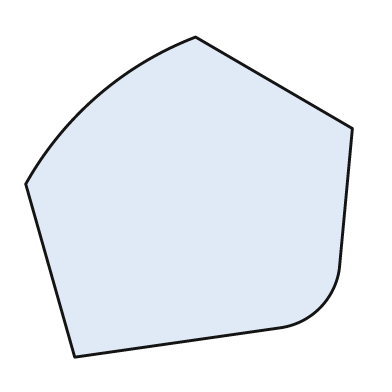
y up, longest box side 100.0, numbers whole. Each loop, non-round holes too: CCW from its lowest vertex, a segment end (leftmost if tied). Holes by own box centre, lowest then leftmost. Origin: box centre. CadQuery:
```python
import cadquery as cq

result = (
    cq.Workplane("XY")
    .moveTo(-35.0, -49.0)
    .lineTo(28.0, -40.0)
    .threePointArc((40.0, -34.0), (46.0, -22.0))
    .lineTo(50.0, 21.0)
    .lineTo(2.0, 49.0)
    .threePointArc((-28.0, 31.0), (-50.0, 4.0))
    .close()
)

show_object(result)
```